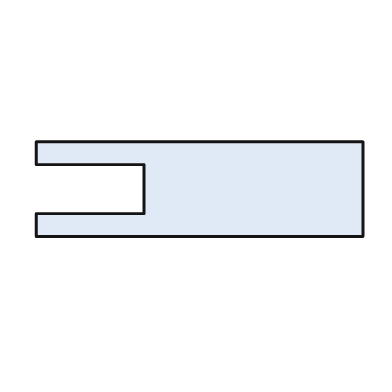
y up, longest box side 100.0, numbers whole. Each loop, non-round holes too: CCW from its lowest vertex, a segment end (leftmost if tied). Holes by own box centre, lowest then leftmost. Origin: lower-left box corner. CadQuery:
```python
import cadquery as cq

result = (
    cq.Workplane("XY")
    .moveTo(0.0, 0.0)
    .lineTo(100.0, 0.0)
    .lineTo(100.0, 29.0)
    .lineTo(0.0, 29.0)
    .lineTo(0.0, 22.0)
    .lineTo(33.0, 22.0)
    .lineTo(33.0, 7.0)
    .lineTo(0.0, 7.0)
    .close()
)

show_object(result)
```